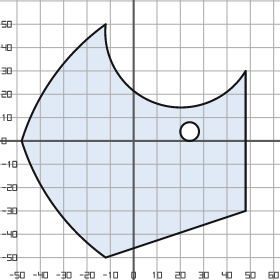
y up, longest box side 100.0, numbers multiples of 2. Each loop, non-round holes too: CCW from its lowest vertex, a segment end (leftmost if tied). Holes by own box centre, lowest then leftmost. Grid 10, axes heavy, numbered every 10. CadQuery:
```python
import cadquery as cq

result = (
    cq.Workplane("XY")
    .moveTo(-12.0, -50.0)
    .lineTo(48.0, -30.0)
    .lineTo(48.0, 30.0)
    .threePointArc((10.0, 16.0), (-12.0, 50.0))
    .threePointArc((-34.0, 28.0), (-48.0, 0.0))
    .threePointArc((-34.0, -28.0), (-12.0, -50.0))
    .close()
    .moveTo(24.0, 4.0)
    .circle(4.0)
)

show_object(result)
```